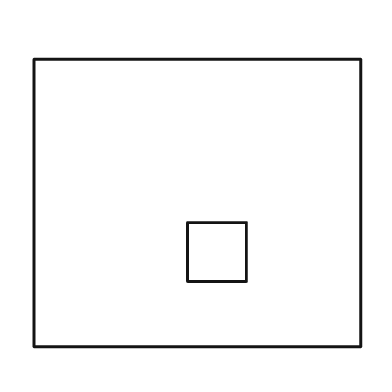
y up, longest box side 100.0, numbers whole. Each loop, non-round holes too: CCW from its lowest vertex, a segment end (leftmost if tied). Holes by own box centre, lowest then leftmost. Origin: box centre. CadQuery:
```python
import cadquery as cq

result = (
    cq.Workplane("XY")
    .moveTo(-50.0, -44.0)
    .lineTo(50.0, -44.0)
    .lineTo(50.0, 44.0)
    .lineTo(-50.0, 44.0)
    .close()
    .moveTo(-3.0, -24.0)
    .lineTo(15.0, -24.0)
    .lineTo(15.0, -6.0)
    .lineTo(-3.0, -6.0)
    .close()
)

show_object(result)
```